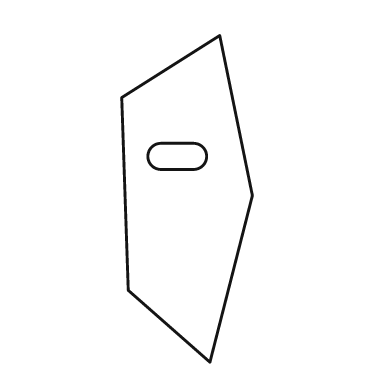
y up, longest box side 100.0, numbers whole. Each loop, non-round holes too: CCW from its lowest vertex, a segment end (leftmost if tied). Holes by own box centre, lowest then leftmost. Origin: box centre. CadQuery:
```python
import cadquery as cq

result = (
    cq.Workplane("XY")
    .moveTo(7.0, -50.0)
    .lineTo(20.0, 1.0)
    .lineTo(10.0, 50.0)
    .lineTo(-20.0, 31.0)
    .lineTo(-18.0, -28.0)
    .close()
    .moveTo(-8.0, 9.0)
    .lineTo(2.0, 9.0)
    .threePointArc((6.0, 13.0), (2.0, 17.0))
    .lineTo(-8.0, 17.0)
    .threePointArc((-12.0, 13.0), (-8.0, 9.0))
    .close()
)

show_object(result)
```